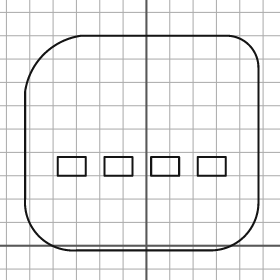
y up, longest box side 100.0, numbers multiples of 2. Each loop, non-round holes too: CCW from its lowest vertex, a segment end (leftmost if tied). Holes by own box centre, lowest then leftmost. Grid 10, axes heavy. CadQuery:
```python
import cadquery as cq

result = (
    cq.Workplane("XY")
    .moveTo(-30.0, -2.0)
    .lineTo(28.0, -2.0)
    .threePointArc((42.0, 4.0), (48.0, 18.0))
    .lineTo(48.0, 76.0)
    .threePointArc((44.0, 86.0), (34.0, 90.0))
    .lineTo(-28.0, 90.0)
    .threePointArc((-44.0, 82.0), (-52.0, 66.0))
    .lineTo(-52.0, 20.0)
    .threePointArc((-46.0, 4.0), (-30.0, -2.0))
    .close()
    .moveTo(-38.0, 30.0)
    .lineTo(-26.0, 30.0)
    .lineTo(-26.0, 38.0)
    .lineTo(-38.0, 38.0)
    .close()
    .moveTo(-18.0, 30.0)
    .lineTo(-6.0, 30.0)
    .lineTo(-6.0, 38.0)
    .lineTo(-18.0, 38.0)
    .close()
    .moveTo(2.0, 30.0)
    .lineTo(14.0, 30.0)
    .lineTo(14.0, 38.0)
    .lineTo(2.0, 38.0)
    .close()
    .moveTo(22.0, 30.0)
    .lineTo(34.0, 30.0)
    .lineTo(34.0, 38.0)
    .lineTo(22.0, 38.0)
    .close()
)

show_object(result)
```